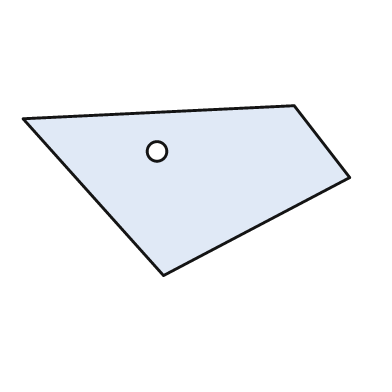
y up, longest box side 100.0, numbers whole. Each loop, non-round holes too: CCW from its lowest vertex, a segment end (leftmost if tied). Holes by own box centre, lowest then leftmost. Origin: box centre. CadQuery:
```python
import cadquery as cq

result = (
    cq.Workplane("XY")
    .moveTo(-7.0, -26.0)
    .lineTo(50.0, 4.0)
    .lineTo(33.0, 26.0)
    .lineTo(-50.0, 22.0)
    .close()
    .moveTo(-9.0, 12.0)
    .circle(3.0)
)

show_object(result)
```